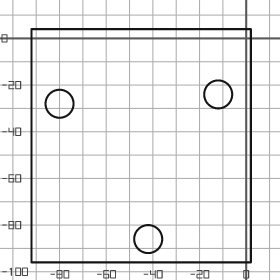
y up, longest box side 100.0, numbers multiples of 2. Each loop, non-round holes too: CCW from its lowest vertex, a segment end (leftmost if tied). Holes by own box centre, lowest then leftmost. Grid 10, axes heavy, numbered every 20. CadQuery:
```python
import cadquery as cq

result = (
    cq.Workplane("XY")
    .moveTo(-92.0, -96.0)
    .lineTo(2.0, -96.0)
    .lineTo(2.0, 4.0)
    .lineTo(-92.0, 4.0)
    .close()
    .moveTo(-42.0, -86.0)
    .circle(6.0)
    .moveTo(-80.0, -28.0)
    .circle(6.0)
    .moveTo(-12.0, -24.0)
    .circle(6.0)
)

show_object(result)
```